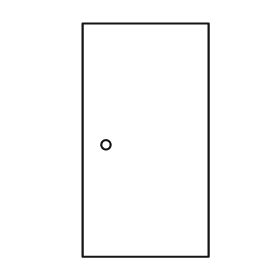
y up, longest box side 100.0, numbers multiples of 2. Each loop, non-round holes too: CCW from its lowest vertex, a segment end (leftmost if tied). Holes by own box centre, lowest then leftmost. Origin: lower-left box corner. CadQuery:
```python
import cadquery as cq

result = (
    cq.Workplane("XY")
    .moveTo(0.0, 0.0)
    .lineTo(54.0, 0.0)
    .lineTo(54.0, 100.0)
    .lineTo(0.0, 100.0)
    .close()
    .moveTo(10.0, 48.0)
    .circle(2.0)
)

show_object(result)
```